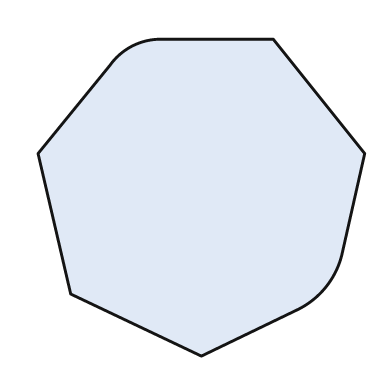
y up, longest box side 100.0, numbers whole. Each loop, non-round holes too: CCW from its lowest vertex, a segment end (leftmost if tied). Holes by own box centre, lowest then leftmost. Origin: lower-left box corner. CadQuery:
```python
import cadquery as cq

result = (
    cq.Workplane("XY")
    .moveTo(50.0, 0.0)
    .lineTo(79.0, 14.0)
    .threePointArc((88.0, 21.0), (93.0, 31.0))
    .lineTo(100.0, 62.0)
    .lineTo(72.0, 97.0)
    .lineTo(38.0, 97.0)
    .threePointArc((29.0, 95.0), (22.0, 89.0))
    .lineTo(0.0, 62.0)
    .lineTo(10.0, 19.0)
    .close()
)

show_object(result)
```